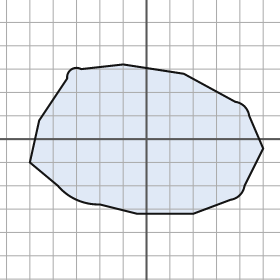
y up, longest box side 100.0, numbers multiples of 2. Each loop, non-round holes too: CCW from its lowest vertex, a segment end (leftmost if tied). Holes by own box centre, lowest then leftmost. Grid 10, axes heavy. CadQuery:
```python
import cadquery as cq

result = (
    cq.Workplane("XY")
    .moveTo(-4.0, -32.0)
    .lineTo(20.0, -32.0)
    .lineTo(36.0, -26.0)
    .threePointArc((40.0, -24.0), (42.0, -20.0))
    .lineTo(50.0, -4.0)
    .lineTo(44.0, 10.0)
    .threePointArc((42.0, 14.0), (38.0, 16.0))
    .lineTo(16.0, 28.0)
    .lineTo(-10.0, 32.0)
    .lineTo(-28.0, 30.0)
    .threePointArc((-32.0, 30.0), (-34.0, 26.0))
    .lineTo(-46.0, 8.0)
    .lineTo(-50.0, -10.0)
    .lineTo(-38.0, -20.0)
    .threePointArc((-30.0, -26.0), (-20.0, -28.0))
    .close()
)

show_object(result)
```